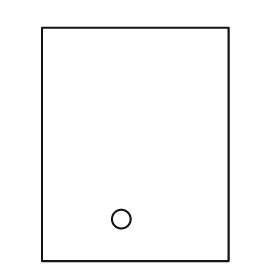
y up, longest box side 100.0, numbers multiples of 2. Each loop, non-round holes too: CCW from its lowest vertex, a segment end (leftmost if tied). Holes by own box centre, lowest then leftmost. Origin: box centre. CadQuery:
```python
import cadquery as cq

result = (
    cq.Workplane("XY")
    .moveTo(-40.0, -50.0)
    .lineTo(40.0, -50.0)
    .lineTo(40.0, 50.0)
    .lineTo(-40.0, 50.0)
    .close()
    .moveTo(-6.0, -32.0)
    .circle(4.0)
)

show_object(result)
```